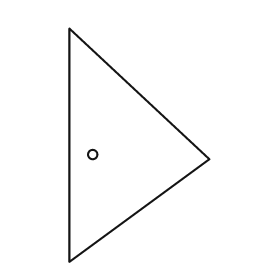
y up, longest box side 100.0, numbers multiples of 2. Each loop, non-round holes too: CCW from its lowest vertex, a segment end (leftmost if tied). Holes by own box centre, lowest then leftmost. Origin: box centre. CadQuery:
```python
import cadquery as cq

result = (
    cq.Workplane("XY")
    .moveTo(-30.0, -50.0)
    .lineTo(30.0, -6.0)
    .lineTo(-30.0, 50.0)
    .close()
    .moveTo(-20.0, -4.0)
    .circle(2.0)
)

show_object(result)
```